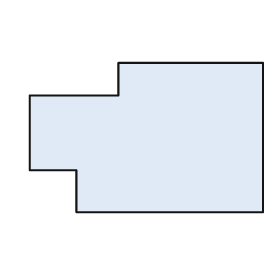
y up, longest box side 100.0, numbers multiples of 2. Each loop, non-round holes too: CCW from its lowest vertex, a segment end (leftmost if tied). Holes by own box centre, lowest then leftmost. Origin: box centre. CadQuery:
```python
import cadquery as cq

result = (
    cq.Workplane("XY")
    .moveTo(-30.0, -32.0)
    .lineTo(50.0, -32.0)
    .lineTo(50.0, 32.0)
    .lineTo(-12.0, 32.0)
    .lineTo(-12.0, 18.0)
    .lineTo(-50.0, 18.0)
    .lineTo(-50.0, -14.0)
    .lineTo(-30.0, -14.0)
    .close()
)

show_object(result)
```